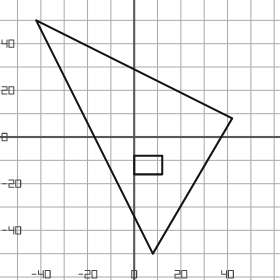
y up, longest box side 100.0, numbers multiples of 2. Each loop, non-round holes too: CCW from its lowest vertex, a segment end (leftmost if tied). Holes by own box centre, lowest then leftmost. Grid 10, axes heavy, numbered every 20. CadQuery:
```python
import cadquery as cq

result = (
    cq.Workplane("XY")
    .moveTo(8.0, -50.0)
    .lineTo(42.0, 8.0)
    .lineTo(-42.0, 50.0)
    .close()
    .moveTo(0.0, -16.0)
    .lineTo(12.0, -16.0)
    .lineTo(12.0, -8.0)
    .lineTo(0.0, -8.0)
    .close()
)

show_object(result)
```